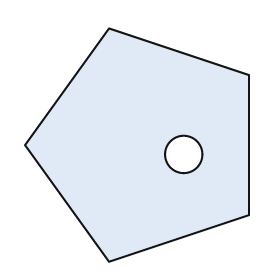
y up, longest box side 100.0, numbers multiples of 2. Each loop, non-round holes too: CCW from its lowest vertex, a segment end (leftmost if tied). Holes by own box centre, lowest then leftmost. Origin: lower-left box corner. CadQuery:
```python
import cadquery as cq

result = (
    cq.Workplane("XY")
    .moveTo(36.0, 0.0)
    .lineTo(96.0, 20.0)
    .lineTo(96.0, 80.0)
    .lineTo(36.0, 100.0)
    .lineTo(0.0, 50.0)
    .close()
    .moveTo(68.0, 46.0)
    .circle(8.0)
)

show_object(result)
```